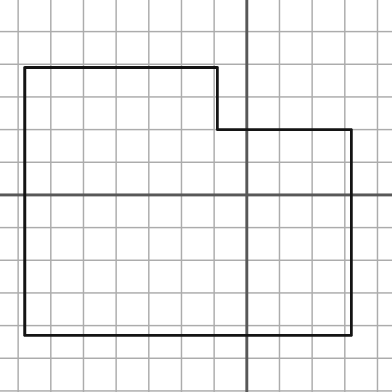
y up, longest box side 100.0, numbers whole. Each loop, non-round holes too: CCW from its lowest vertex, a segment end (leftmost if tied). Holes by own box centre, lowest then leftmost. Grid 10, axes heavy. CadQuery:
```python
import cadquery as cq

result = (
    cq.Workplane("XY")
    .moveTo(-68.0, -43.0)
    .lineTo(32.0, -43.0)
    .lineTo(32.0, 20.0)
    .lineTo(-9.0, 20.0)
    .lineTo(-9.0, 39.0)
    .lineTo(-68.0, 39.0)
    .close()
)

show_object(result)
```